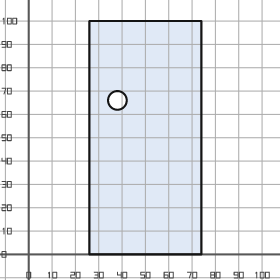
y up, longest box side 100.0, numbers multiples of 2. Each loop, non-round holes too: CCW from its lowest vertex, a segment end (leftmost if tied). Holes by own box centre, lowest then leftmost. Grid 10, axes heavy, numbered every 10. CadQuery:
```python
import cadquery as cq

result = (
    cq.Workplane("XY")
    .moveTo(26.0, 0.0)
    .lineTo(74.0, 0.0)
    .lineTo(74.0, 100.0)
    .lineTo(26.0, 100.0)
    .close()
    .moveTo(38.0, 66.0)
    .circle(4.0)
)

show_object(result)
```